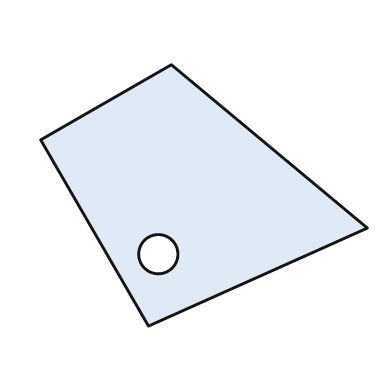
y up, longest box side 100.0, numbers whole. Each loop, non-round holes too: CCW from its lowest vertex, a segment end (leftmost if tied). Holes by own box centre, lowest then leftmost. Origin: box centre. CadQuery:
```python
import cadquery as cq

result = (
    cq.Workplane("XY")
    .moveTo(-17.0, -40.0)
    .lineTo(50.0, -10.0)
    .lineTo(-10.0, 40.0)
    .lineTo(-50.0, 17.0)
    .close()
    .moveTo(-14.0, -18.0)
    .circle(6.0)
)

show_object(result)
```